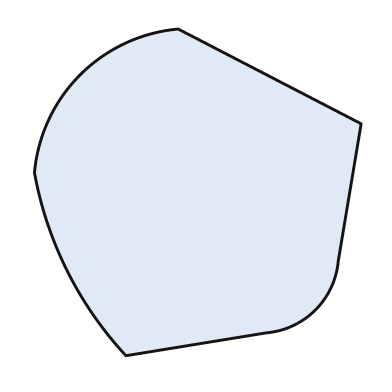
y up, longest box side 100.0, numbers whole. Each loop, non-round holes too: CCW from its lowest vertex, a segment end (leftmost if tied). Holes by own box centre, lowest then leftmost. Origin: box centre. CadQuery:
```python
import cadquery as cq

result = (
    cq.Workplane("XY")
    .moveTo(-22.0, -50.0)
    .lineTo(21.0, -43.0)
    .threePointArc((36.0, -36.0), (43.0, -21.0))
    .lineTo(50.0, 21.0)
    .lineTo(-6.0, 50.0)
    .threePointArc((-36.0, 36.0), (-50.0, 6.0))
    .threePointArc((-40.0, -24.0), (-22.0, -50.0))
    .close()
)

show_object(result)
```